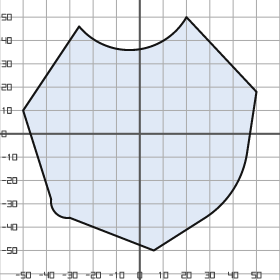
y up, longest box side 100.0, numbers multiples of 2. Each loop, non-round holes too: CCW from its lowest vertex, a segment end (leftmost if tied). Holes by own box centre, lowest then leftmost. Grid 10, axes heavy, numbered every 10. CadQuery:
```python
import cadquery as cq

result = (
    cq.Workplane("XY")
    .moveTo(6.0, -50.0)
    .lineTo(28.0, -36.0)
    .threePointArc((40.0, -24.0), (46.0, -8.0))
    .lineTo(50.0, 18.0)
    .lineTo(20.0, 50.0)
    .threePointArc((-2.0, 36.0), (-26.0, 46.0))
    .lineTo(-50.0, 10.0)
    .lineTo(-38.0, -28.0)
    .threePointArc((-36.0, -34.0), (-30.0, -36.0))
    .close()
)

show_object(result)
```